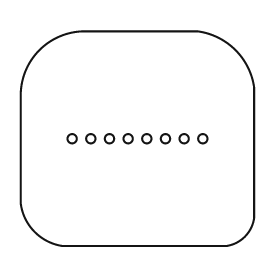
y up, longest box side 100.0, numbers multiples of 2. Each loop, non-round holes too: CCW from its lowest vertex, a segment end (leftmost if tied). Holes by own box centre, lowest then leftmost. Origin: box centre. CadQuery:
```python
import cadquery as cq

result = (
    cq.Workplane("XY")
    .moveTo(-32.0, -46.0)
    .lineTo(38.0, -46.0)
    .threePointArc((46.0, -42.0), (50.0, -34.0))
    .lineTo(50.0, 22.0)
    .threePointArc((42.0, 38.0), (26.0, 46.0))
    .lineTo(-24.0, 46.0)
    .threePointArc((-42.0, 38.0), (-50.0, 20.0))
    .lineTo(-50.0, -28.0)
    .threePointArc((-44.0, -40.0), (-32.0, -46.0))
    .close()
    .moveTo(-28.0, 0.0)
    .circle(2.0)
    .moveTo(-20.0, 0.0)
    .circle(2.0)
    .moveTo(-12.0, 0.0)
    .circle(2.0)
    .moveTo(-4.0, 0.0)
    .circle(2.0)
    .moveTo(4.0, 0.0)
    .circle(2.0)
    .moveTo(12.0, 0.0)
    .circle(2.0)
    .moveTo(20.0, 0.0)
    .circle(2.0)
    .moveTo(28.0, 0.0)
    .circle(2.0)
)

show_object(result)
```